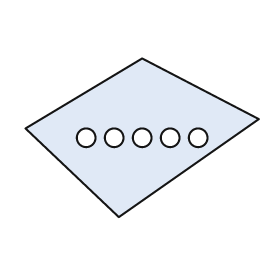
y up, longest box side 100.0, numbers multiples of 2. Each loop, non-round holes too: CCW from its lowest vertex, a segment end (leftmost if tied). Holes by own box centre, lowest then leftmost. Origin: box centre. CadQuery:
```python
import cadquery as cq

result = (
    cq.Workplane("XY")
    .moveTo(-10.0, -34.0)
    .lineTo(50.0, 8.0)
    .lineTo(0.0, 34.0)
    .lineTo(-50.0, 4.0)
    .close()
    .moveTo(-24.0, 0.0)
    .circle(4.0)
    .moveTo(-12.0, 0.0)
    .circle(4.0)
    .moveTo(0.0, 0.0)
    .circle(4.0)
    .moveTo(12.0, 0.0)
    .circle(4.0)
    .moveTo(24.0, 0.0)
    .circle(4.0)
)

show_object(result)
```